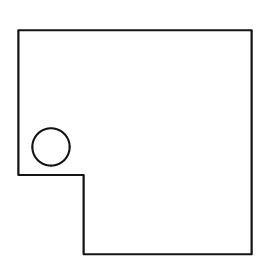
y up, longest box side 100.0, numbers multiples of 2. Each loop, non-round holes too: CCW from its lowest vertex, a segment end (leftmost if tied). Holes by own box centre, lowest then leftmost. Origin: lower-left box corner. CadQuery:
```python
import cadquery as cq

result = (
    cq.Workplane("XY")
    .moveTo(28.0, 0.0)
    .lineTo(100.0, 0.0)
    .lineTo(100.0, 96.0)
    .lineTo(0.0, 96.0)
    .lineTo(0.0, 34.0)
    .lineTo(28.0, 34.0)
    .close()
    .moveTo(14.0, 46.0)
    .circle(8.0)
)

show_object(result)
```